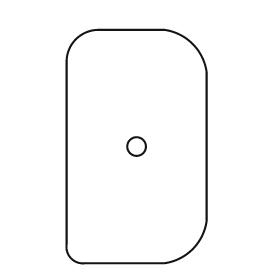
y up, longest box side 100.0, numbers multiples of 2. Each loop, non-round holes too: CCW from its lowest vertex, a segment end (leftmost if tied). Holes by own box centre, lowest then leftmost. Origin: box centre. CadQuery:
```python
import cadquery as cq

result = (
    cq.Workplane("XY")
    .moveTo(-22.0, -50.0)
    .lineTo(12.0, -50.0)
    .threePointArc((24.0, -44.0), (30.0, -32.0))
    .lineTo(30.0, 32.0)
    .threePointArc((24.0, 44.0), (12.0, 50.0))
    .lineTo(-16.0, 50.0)
    .threePointArc((-26.0, 46.0), (-30.0, 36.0))
    .lineTo(-30.0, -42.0)
    .threePointArc((-28.0, -48.0), (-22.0, -50.0))
    .close()
    .moveTo(0.0, 0.0)
    .circle(4.0)
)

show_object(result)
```